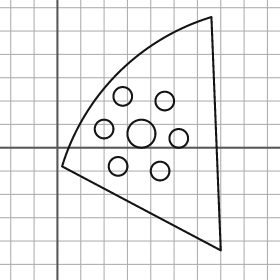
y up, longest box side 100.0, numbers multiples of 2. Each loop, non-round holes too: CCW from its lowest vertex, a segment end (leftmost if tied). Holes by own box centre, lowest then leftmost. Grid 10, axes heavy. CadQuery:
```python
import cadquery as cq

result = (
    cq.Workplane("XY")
    .moveTo(70.0, -44.0)
    .lineTo(66.0, 56.0)
    .threePointArc((26.0, 32.0), (2.0, -8.0))
    .close()
    .moveTo(44.0, -10.0)
    .circle(4.0)
    .moveTo(26.0, -8.0)
    .circle(4.0)
    .moveTo(52.0, 4.0)
    .circle(4.0)
    .moveTo(36.0, 6.0)
    .circle(6.0)
    .moveTo(20.0, 8.0)
    .circle(4.0)
    .moveTo(46.0, 20.0)
    .circle(4.0)
    .moveTo(28.0, 22.0)
    .circle(4.0)
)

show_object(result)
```